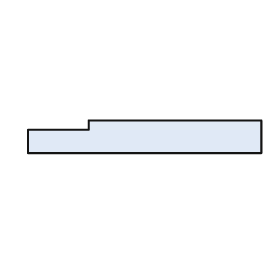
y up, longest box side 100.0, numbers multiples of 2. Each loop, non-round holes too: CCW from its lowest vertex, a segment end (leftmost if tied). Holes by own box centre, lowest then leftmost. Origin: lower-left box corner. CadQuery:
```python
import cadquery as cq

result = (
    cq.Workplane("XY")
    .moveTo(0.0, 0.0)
    .lineTo(100.0, 0.0)
    .lineTo(100.0, 14.0)
    .lineTo(26.0, 14.0)
    .lineTo(26.0, 10.0)
    .lineTo(0.0, 10.0)
    .close()
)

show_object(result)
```